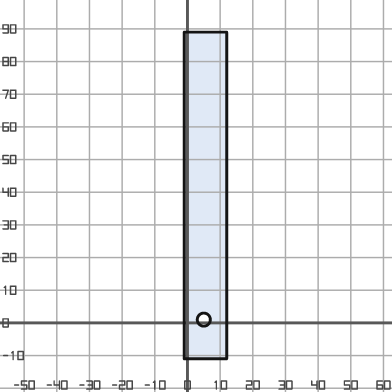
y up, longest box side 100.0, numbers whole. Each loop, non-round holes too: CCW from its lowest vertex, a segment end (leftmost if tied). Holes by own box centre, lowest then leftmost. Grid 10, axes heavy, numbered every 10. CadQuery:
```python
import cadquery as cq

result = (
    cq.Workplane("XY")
    .moveTo(-1.0, -11.0)
    .lineTo(12.0, -11.0)
    .lineTo(12.0, 89.0)
    .lineTo(-1.0, 89.0)
    .close()
    .moveTo(5.0, 1.0)
    .circle(2.0)
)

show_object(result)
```